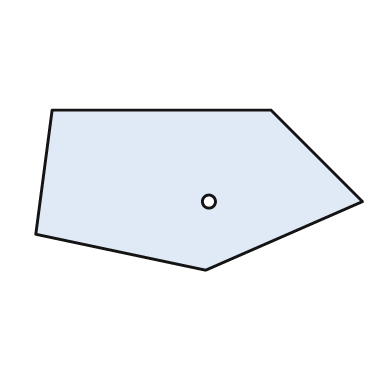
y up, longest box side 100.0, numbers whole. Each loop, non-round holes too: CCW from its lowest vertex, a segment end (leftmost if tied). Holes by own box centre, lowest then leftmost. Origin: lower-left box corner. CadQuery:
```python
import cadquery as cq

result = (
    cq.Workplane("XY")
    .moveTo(52.0, 0.0)
    .lineTo(100.0, 21.0)
    .lineTo(72.0, 49.0)
    .lineTo(5.0, 49.0)
    .lineTo(0.0, 11.0)
    .close()
    .moveTo(53.0, 21.0)
    .circle(2.0)
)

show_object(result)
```